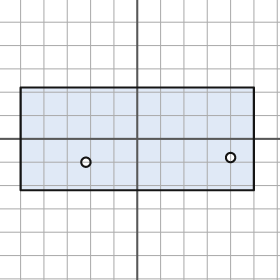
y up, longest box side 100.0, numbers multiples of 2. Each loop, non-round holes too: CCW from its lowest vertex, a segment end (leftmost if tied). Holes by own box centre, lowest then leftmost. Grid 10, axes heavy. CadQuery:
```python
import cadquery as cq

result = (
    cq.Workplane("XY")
    .moveTo(-50.0, -22.0)
    .lineTo(50.0, -22.0)
    .lineTo(50.0, 22.0)
    .lineTo(-50.0, 22.0)
    .close()
    .moveTo(-22.0, -10.0)
    .circle(2.0)
    .moveTo(40.0, -8.0)
    .circle(2.0)
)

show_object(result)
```